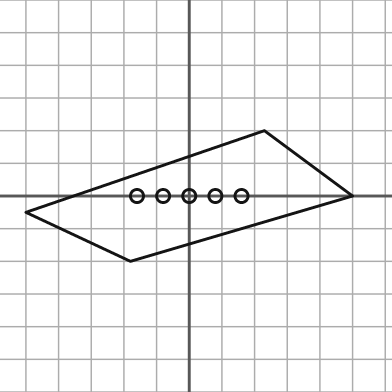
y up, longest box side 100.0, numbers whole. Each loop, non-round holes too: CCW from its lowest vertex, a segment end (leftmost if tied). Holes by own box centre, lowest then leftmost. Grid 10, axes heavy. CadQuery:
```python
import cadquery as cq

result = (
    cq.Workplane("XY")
    .moveTo(-18.0, -20.0)
    .lineTo(50.0, 0.0)
    .lineTo(23.0, 20.0)
    .lineTo(-50.0, -5.0)
    .close()
    .moveTo(-16.0, 0.0)
    .circle(2.0)
    .moveTo(-8.0, 0.0)
    .circle(2.0)
    .moveTo(0.0, 0.0)
    .circle(2.0)
    .moveTo(8.0, 0.0)
    .circle(2.0)
    .moveTo(16.0, 0.0)
    .circle(2.0)
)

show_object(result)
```